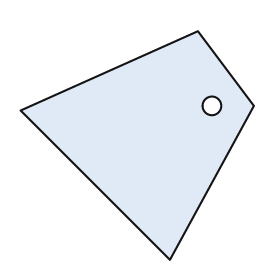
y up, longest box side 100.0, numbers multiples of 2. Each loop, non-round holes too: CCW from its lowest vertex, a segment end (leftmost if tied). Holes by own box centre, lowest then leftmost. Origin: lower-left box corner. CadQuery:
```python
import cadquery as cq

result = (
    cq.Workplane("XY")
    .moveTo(64.0, 0.0)
    .lineTo(100.0, 66.0)
    .lineTo(76.0, 98.0)
    .lineTo(0.0, 64.0)
    .close()
    .moveTo(82.0, 66.0)
    .circle(4.0)
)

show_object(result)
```